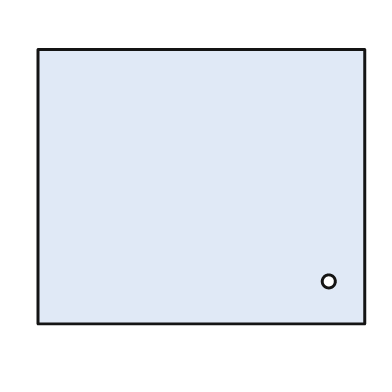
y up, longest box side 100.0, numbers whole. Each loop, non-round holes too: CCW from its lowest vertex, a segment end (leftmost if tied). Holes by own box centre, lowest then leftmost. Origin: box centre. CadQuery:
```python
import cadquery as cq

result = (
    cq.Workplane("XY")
    .moveTo(-50.0, -42.0)
    .lineTo(50.0, -42.0)
    .lineTo(50.0, 42.0)
    .lineTo(-50.0, 42.0)
    .close()
    .moveTo(39.0, -29.0)
    .circle(2.0)
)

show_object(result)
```